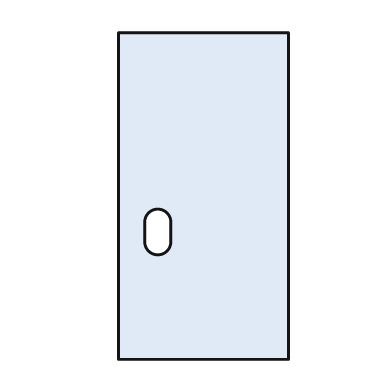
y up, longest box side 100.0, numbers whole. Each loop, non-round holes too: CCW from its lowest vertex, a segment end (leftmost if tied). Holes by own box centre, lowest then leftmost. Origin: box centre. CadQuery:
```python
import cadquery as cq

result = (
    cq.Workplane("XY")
    .moveTo(-26.0, -50.0)
    .lineTo(26.0, -50.0)
    .lineTo(26.0, 50.0)
    .lineTo(-26.0, 50.0)
    .close()
    .moveTo(-18.0, -14.0)
    .threePointArc((-14.0, -18.0), (-10.0, -14.0))
    .lineTo(-10.0, -8.0)
    .threePointArc((-14.0, -4.0), (-18.0, -8.0))
    .close()
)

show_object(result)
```